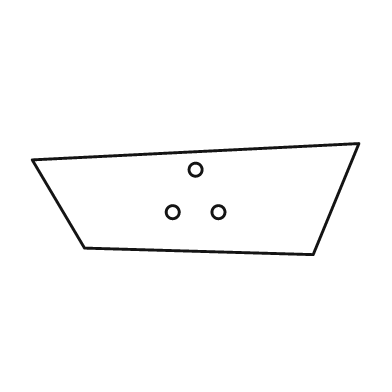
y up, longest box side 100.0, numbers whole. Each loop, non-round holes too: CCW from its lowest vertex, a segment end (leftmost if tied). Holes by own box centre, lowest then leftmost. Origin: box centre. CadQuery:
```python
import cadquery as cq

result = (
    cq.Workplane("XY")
    .moveTo(36.0, -17.0)
    .lineTo(50.0, 17.0)
    .lineTo(-50.0, 12.0)
    .lineTo(-34.0, -15.0)
    .close()
    .moveTo(-7.0, -4.0)
    .circle(2.0)
    .moveTo(7.0, -4.0)
    .circle(2.0)
    .moveTo(0.0, 9.0)
    .circle(2.0)
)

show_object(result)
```